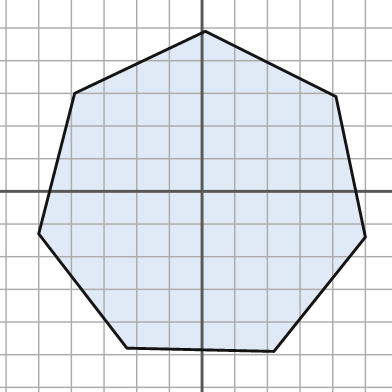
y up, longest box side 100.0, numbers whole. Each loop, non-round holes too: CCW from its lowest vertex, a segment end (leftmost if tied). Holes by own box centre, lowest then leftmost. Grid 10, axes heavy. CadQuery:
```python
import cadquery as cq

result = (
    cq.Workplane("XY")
    .moveTo(22.0, -49.0)
    .lineTo(50.0, -14.0)
    .lineTo(41.0, 29.0)
    .lineTo(1.0, 49.0)
    .lineTo(-39.0, 30.0)
    .lineTo(-50.0, -13.0)
    .lineTo(-23.0, -48.0)
    .close()
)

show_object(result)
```